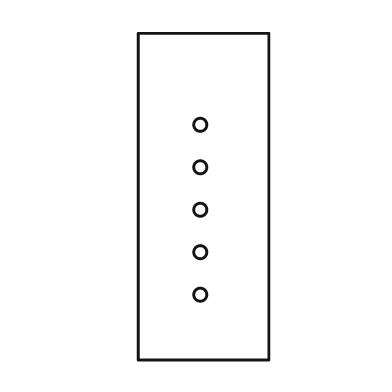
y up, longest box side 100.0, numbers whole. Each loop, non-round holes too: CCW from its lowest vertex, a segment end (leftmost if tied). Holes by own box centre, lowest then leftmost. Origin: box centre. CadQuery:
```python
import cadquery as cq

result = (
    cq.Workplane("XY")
    .moveTo(-20.0, -50.0)
    .lineTo(20.0, -50.0)
    .lineTo(20.0, 50.0)
    .lineTo(-20.0, 50.0)
    .close()
    .moveTo(-1.0, -30.0)
    .circle(2.0)
    .moveTo(-1.0, -17.0)
    .circle(2.0)
    .moveTo(-1.0, -4.0)
    .circle(2.0)
    .moveTo(-1.0, 9.0)
    .circle(2.0)
    .moveTo(-1.0, 22.0)
    .circle(2.0)
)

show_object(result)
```